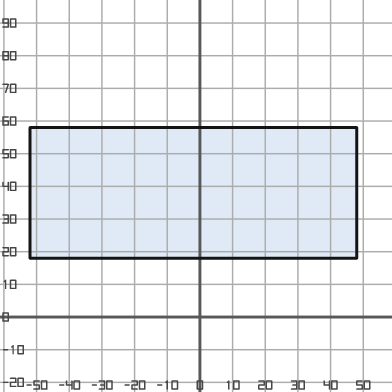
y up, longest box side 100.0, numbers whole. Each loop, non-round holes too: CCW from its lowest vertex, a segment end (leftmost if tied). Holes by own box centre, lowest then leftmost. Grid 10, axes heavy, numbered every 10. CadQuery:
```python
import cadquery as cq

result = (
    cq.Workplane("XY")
    .moveTo(-52.0, 18.0)
    .lineTo(48.0, 18.0)
    .lineTo(48.0, 58.0)
    .lineTo(-52.0, 58.0)
    .close()
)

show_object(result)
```